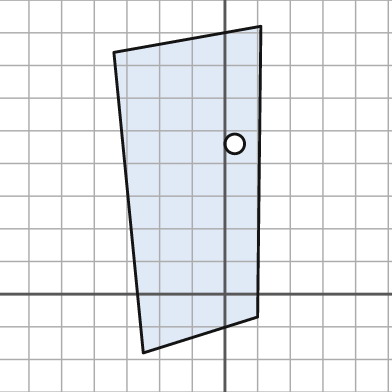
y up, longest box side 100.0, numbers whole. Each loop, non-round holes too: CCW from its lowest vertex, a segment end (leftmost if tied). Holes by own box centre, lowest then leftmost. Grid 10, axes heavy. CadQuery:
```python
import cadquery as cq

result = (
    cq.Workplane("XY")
    .moveTo(-25.0, -18.0)
    .lineTo(10.0, -7.0)
    .lineTo(11.0, 82.0)
    .lineTo(-34.0, 74.0)
    .close()
    .moveTo(3.0, 46.0)
    .circle(3.0)
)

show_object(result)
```